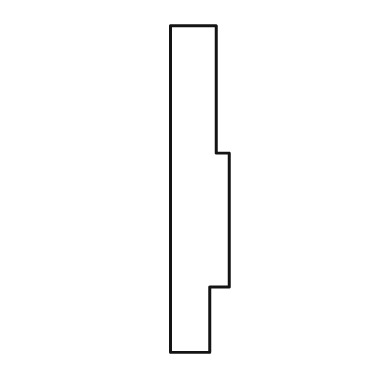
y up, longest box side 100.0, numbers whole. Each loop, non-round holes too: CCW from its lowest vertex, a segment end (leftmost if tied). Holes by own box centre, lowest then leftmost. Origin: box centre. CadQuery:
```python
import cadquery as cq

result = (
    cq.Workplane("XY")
    .moveTo(-9.0, -50.0)
    .lineTo(3.0, -50.0)
    .lineTo(3.0, -30.0)
    .lineTo(9.0, -30.0)
    .lineTo(9.0, 11.0)
    .lineTo(5.0, 11.0)
    .lineTo(5.0, 50.0)
    .lineTo(-9.0, 50.0)
    .close()
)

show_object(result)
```